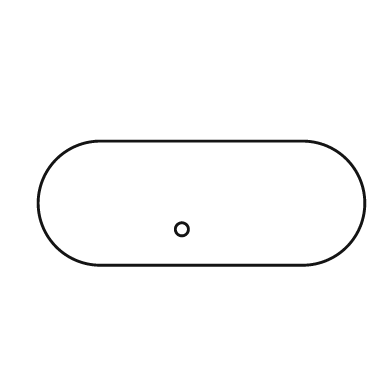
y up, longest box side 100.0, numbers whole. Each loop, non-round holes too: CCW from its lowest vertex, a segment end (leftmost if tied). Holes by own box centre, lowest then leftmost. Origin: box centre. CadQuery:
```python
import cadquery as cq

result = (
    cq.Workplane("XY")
    .moveTo(-31.0, -19.0)
    .lineTo(31.0, -19.0)
    .threePointArc((50.0, 0.0), (31.0, 19.0))
    .lineTo(-31.0, 19.0)
    .threePointArc((-50.0, 0.0), (-31.0, -19.0))
    .close()
    .moveTo(-6.0, -8.0)
    .circle(2.0)
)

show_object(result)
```